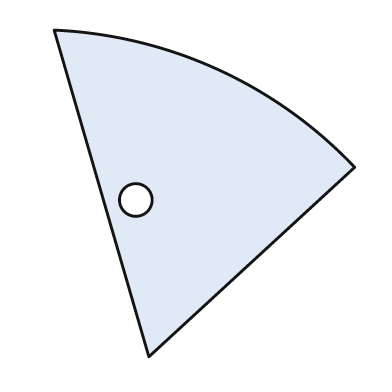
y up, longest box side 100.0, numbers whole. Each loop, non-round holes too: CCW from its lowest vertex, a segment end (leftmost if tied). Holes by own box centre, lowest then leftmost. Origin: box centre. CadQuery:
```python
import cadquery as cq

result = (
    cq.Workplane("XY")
    .moveTo(-17.0, -50.0)
    .lineTo(46.0, 8.0)
    .threePointArc((4.0, 38.0), (-46.0, 50.0))
    .close()
    .moveTo(-21.0, -2.0)
    .circle(5.0)
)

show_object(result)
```